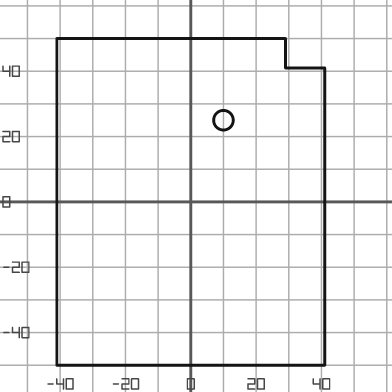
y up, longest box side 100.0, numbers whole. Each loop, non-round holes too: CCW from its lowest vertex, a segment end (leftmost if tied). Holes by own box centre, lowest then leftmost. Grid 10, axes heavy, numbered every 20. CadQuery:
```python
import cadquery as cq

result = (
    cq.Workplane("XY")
    .moveTo(-41.0, -50.0)
    .lineTo(41.0, -50.0)
    .lineTo(41.0, 41.0)
    .lineTo(29.0, 41.0)
    .lineTo(29.0, 50.0)
    .lineTo(-41.0, 50.0)
    .close()
    .moveTo(10.0, 25.0)
    .circle(3.0)
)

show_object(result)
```